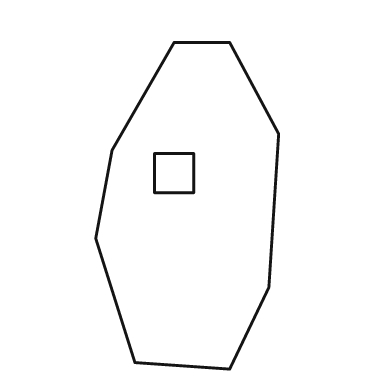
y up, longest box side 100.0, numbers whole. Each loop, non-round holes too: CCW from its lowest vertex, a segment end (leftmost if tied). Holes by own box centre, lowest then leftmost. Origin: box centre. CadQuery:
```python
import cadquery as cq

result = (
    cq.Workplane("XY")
    .moveTo(13.0, -50.0)
    .lineTo(25.0, -25.0)
    .lineTo(28.0, 22.0)
    .lineTo(13.0, 50.0)
    .lineTo(-4.0, 50.0)
    .lineTo(-23.0, 17.0)
    .lineTo(-28.0, -10.0)
    .lineTo(-16.0, -48.0)
    .close()
    .moveTo(-10.0, 4.0)
    .lineTo(2.0, 4.0)
    .lineTo(2.0, 16.0)
    .lineTo(-10.0, 16.0)
    .close()
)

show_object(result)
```